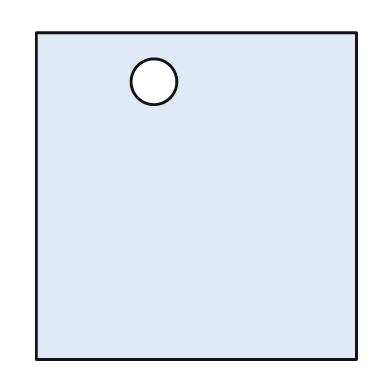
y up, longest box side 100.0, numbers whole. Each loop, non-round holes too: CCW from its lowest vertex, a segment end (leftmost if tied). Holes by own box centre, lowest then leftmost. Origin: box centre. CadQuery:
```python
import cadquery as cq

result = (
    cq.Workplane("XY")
    .moveTo(-49.0, -50.0)
    .lineTo(49.0, -50.0)
    .lineTo(49.0, 50.0)
    .lineTo(-49.0, 50.0)
    .close()
    .moveTo(-13.0, 35.0)
    .circle(7.0)
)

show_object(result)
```